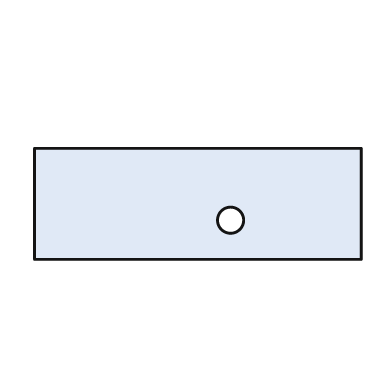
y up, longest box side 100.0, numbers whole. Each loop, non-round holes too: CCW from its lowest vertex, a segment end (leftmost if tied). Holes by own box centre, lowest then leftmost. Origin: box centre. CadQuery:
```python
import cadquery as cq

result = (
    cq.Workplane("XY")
    .moveTo(-50.0, -17.0)
    .lineTo(50.0, -17.0)
    .lineTo(50.0, 17.0)
    .lineTo(-50.0, 17.0)
    .close()
    .moveTo(10.0, -5.0)
    .circle(4.0)
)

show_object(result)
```